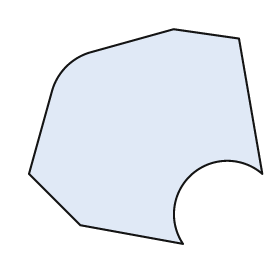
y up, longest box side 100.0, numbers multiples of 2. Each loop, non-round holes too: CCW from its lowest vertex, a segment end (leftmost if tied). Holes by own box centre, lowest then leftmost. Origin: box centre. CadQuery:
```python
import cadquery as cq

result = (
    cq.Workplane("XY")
    .moveTo(16.0, -46.0)
    .threePointArc((20.0, -16.0), (50.0, -16.0))
    .lineTo(40.0, 42.0)
    .lineTo(12.0, 46.0)
    .lineTo(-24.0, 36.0)
    .threePointArc((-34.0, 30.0), (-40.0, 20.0))
    .lineTo(-50.0, -16.0)
    .lineTo(-28.0, -38.0)
    .close()
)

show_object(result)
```